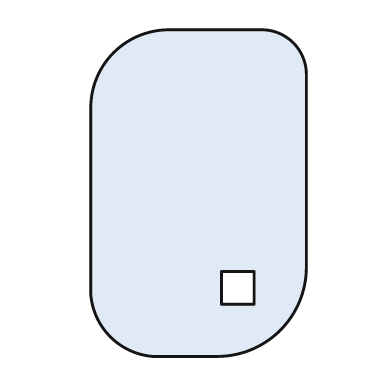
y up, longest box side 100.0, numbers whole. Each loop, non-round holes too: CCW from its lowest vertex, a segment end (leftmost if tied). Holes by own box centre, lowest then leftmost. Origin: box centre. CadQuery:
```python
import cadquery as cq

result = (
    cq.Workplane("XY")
    .moveTo(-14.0, -50.0)
    .lineTo(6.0, -50.0)
    .threePointArc((25.0, -42.0), (33.0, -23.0))
    .lineTo(33.0, 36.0)
    .threePointArc((29.0, 46.0), (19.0, 50.0))
    .lineTo(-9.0, 50.0)
    .threePointArc((-26.0, 43.0), (-33.0, 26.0))
    .lineTo(-33.0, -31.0)
    .threePointArc((-27.0, -44.0), (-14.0, -50.0))
    .close()
    .moveTo(7.0, -34.0)
    .lineTo(17.0, -34.0)
    .lineTo(17.0, -24.0)
    .lineTo(7.0, -24.0)
    .close()
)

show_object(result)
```